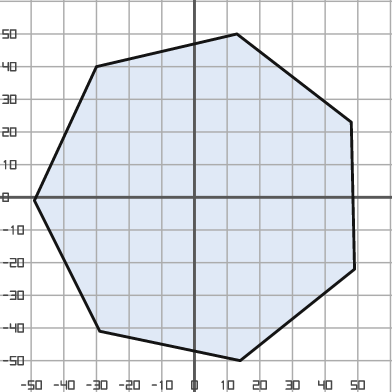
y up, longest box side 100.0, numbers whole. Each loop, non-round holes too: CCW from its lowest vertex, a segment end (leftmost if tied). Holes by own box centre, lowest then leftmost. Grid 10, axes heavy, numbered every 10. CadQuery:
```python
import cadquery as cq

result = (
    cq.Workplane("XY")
    .moveTo(14.0, -50.0)
    .lineTo(49.0, -22.0)
    .lineTo(48.0, 23.0)
    .lineTo(13.0, 50.0)
    .lineTo(-30.0, 40.0)
    .lineTo(-49.0, -1.0)
    .lineTo(-29.0, -41.0)
    .close()
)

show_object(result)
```